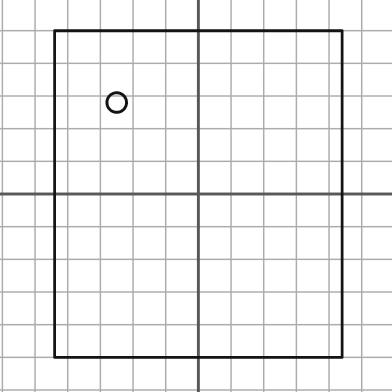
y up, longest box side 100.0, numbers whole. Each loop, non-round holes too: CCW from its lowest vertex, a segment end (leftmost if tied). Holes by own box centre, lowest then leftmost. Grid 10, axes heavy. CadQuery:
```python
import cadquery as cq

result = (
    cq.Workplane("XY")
    .moveTo(-44.0, -50.0)
    .lineTo(44.0, -50.0)
    .lineTo(44.0, 50.0)
    .lineTo(-44.0, 50.0)
    .close()
    .moveTo(-25.0, 28.0)
    .circle(3.0)
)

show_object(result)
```